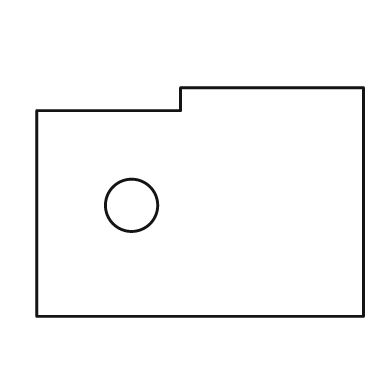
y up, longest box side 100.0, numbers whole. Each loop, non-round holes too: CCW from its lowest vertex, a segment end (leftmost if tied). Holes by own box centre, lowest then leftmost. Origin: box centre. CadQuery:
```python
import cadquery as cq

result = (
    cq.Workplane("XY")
    .moveTo(-50.0, -35.0)
    .lineTo(50.0, -35.0)
    .lineTo(50.0, 35.0)
    .lineTo(-6.0, 35.0)
    .lineTo(-6.0, 28.0)
    .lineTo(-50.0, 28.0)
    .close()
    .moveTo(-21.0, -1.0)
    .circle(8.0)
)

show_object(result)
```